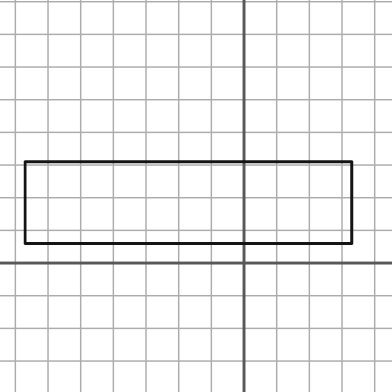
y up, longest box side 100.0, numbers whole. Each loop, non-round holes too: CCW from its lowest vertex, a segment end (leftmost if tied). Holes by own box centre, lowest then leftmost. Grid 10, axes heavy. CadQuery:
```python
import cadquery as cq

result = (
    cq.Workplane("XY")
    .moveTo(-67.0, 6.0)
    .lineTo(33.0, 6.0)
    .lineTo(33.0, 31.0)
    .lineTo(-67.0, 31.0)
    .close()
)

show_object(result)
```